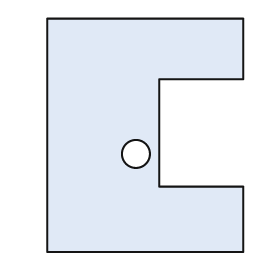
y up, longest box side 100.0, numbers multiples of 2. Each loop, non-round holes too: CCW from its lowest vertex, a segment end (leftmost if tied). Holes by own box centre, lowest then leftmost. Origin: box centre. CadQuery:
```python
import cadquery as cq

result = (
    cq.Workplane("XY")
    .moveTo(-42.0, -50.0)
    .lineTo(42.0, -50.0)
    .lineTo(42.0, -22.0)
    .lineTo(6.0, -22.0)
    .lineTo(6.0, 24.0)
    .lineTo(42.0, 24.0)
    .lineTo(42.0, 50.0)
    .lineTo(-42.0, 50.0)
    .close()
    .moveTo(-4.0, -8.0)
    .circle(6.0)
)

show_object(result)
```